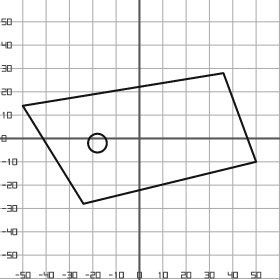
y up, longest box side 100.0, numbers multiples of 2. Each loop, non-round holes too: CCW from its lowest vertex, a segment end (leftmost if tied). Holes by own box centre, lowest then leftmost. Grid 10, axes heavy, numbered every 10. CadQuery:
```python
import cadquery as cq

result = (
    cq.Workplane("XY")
    .moveTo(-24.0, -28.0)
    .lineTo(50.0, -10.0)
    .lineTo(36.0, 28.0)
    .lineTo(-50.0, 14.0)
    .close()
    .moveTo(-18.0, -2.0)
    .circle(4.0)
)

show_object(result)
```